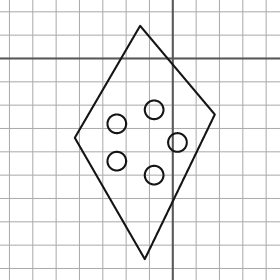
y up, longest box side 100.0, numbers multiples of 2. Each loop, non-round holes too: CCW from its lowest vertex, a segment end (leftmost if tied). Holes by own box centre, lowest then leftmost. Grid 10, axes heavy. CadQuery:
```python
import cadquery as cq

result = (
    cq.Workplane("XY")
    .moveTo(-12.0, -86.0)
    .lineTo(18.0, -24.0)
    .lineTo(-14.0, 14.0)
    .lineTo(-42.0, -34.0)
    .close()
    .moveTo(-8.0, -50.0)
    .circle(4.0)
    .moveTo(-24.0, -44.0)
    .circle(4.0)
    .moveTo(2.0, -36.0)
    .circle(4.0)
    .moveTo(-24.0, -28.0)
    .circle(4.0)
    .moveTo(-8.0, -22.0)
    .circle(4.0)
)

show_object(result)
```